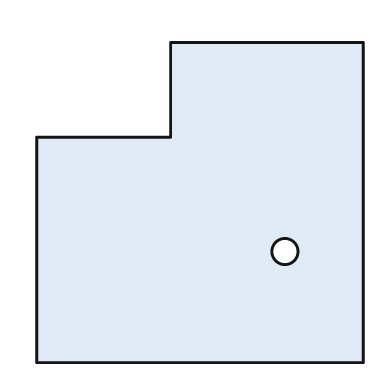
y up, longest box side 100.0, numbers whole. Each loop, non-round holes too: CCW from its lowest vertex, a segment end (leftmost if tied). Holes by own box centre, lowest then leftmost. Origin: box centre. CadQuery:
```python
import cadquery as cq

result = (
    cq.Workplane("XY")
    .moveTo(-50.0, -49.0)
    .lineTo(50.0, -49.0)
    .lineTo(50.0, 49.0)
    .lineTo(-9.0, 49.0)
    .lineTo(-9.0, 20.0)
    .lineTo(-50.0, 20.0)
    .close()
    .moveTo(26.0, -15.0)
    .circle(4.0)
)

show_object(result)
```